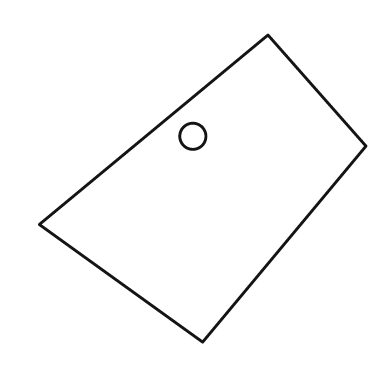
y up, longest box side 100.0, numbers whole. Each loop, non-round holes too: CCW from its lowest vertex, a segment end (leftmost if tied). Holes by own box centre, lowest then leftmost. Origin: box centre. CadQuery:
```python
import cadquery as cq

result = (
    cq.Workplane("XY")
    .moveTo(0.0, -47.0)
    .lineTo(50.0, 13.0)
    .lineTo(20.0, 47.0)
    .lineTo(-50.0, -11.0)
    .close()
    .moveTo(-3.0, 16.0)
    .circle(4.0)
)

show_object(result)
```